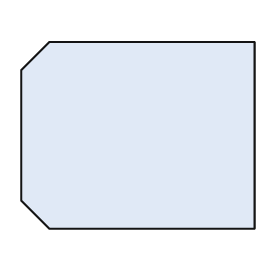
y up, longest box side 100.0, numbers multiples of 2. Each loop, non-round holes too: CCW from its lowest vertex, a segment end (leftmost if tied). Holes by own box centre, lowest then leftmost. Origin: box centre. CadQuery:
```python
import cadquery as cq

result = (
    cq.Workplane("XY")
    .moveTo(-38.0, -40.0)
    .lineTo(50.0, -40.0)
    .lineTo(50.0, 40.0)
    .lineTo(-38.0, 40.0)
    .lineTo(-50.0, 28.0)
    .lineTo(-50.0, -28.0)
    .close()
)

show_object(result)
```